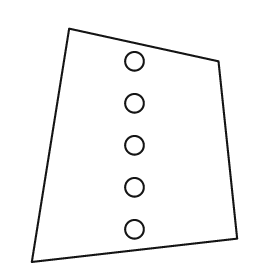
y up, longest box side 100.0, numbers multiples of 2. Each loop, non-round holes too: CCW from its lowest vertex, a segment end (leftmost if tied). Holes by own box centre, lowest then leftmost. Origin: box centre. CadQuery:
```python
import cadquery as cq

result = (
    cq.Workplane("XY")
    .moveTo(-44.0, -50.0)
    .lineTo(44.0, -40.0)
    .lineTo(36.0, 36.0)
    .lineTo(-28.0, 50.0)
    .close()
    .moveTo(0.0, -36.0)
    .circle(4.0)
    .moveTo(0.0, -18.0)
    .circle(4.0)
    .moveTo(0.0, 0.0)
    .circle(4.0)
    .moveTo(0.0, 18.0)
    .circle(4.0)
    .moveTo(0.0, 36.0)
    .circle(4.0)
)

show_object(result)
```